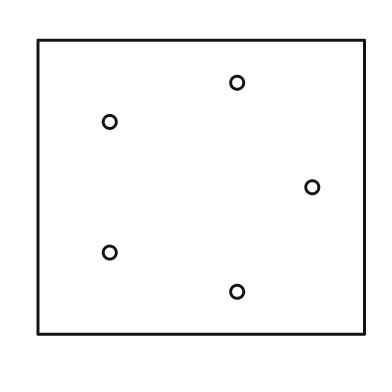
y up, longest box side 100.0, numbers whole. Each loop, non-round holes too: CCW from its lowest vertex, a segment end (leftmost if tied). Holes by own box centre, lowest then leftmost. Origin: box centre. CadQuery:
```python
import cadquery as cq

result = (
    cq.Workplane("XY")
    .moveTo(-50.0, -45.0)
    .lineTo(50.0, -45.0)
    .lineTo(50.0, 45.0)
    .lineTo(-50.0, 45.0)
    .close()
    .moveTo(11.0, -32.0)
    .circle(2.0)
    .moveTo(-28.0, -20.0)
    .circle(2.0)
    .moveTo(34.0, 0.0)
    .circle(2.0)
    .moveTo(-28.0, 20.0)
    .circle(2.0)
    .moveTo(11.0, 32.0)
    .circle(2.0)
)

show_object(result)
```